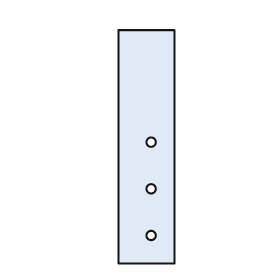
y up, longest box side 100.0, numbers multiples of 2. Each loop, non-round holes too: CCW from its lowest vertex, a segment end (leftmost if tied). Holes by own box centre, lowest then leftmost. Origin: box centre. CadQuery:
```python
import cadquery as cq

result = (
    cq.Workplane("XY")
    .moveTo(-12.0, -50.0)
    .lineTo(12.0, -50.0)
    .lineTo(12.0, 50.0)
    .lineTo(-12.0, 50.0)
    .close()
    .moveTo(2.0, -38.0)
    .circle(2.0)
    .moveTo(2.0, -18.0)
    .circle(2.0)
    .moveTo(2.0, 2.0)
    .circle(2.0)
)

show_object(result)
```